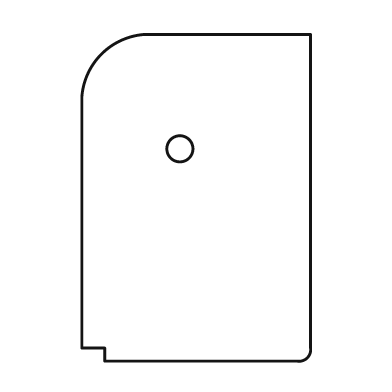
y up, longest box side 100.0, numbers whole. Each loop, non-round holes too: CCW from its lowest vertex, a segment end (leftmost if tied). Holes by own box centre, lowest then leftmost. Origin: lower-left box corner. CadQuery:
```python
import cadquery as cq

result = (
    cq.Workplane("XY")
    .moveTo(7.0, 0.0)
    .lineTo(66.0, 0.0)
    .threePointArc((69.0, 1.0), (70.0, 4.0))
    .lineTo(70.0, 100.0)
    .lineTo(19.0, 100.0)
    .threePointArc((6.0, 94.0), (0.0, 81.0))
    .lineTo(0.0, 4.0)
    .lineTo(7.0, 4.0)
    .close()
    .moveTo(30.0, 65.0)
    .circle(4.0)
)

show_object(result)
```